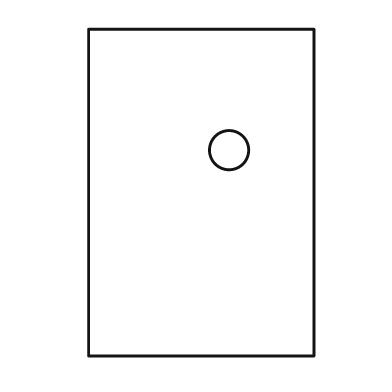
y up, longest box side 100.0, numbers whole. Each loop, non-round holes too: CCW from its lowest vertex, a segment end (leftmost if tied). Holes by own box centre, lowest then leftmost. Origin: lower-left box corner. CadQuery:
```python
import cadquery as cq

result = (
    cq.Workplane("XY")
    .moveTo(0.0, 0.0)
    .lineTo(69.0, 0.0)
    .lineTo(69.0, 100.0)
    .lineTo(0.0, 100.0)
    .close()
    .moveTo(43.0, 63.0)
    .circle(6.0)
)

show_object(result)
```